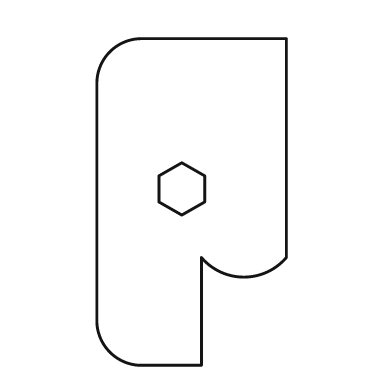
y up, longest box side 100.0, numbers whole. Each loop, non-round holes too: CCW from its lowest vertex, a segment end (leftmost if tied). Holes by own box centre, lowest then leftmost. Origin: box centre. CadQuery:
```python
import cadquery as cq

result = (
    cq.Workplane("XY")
    .moveTo(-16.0, -50.0)
    .lineTo(3.0, -50.0)
    .lineTo(3.0, -17.0)
    .threePointArc((16.0, -23.0), (29.0, -17.0))
    .lineTo(29.0, 50.0)
    .lineTo(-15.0, 50.0)
    .threePointArc((-25.0, 46.0), (-29.0, 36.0))
    .lineTo(-29.0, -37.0)
    .threePointArc((-25.0, -46.0), (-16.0, -50.0))
    .close()
    .moveTo(-3.0, -4.0)
    .lineTo(4.0, 0.0)
    .lineTo(4.0, 8.0)
    .lineTo(-3.0, 12.0)
    .lineTo(-10.0, 8.0)
    .lineTo(-10.0, 0.0)
    .close()
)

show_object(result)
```